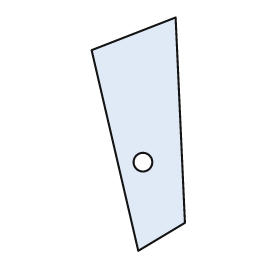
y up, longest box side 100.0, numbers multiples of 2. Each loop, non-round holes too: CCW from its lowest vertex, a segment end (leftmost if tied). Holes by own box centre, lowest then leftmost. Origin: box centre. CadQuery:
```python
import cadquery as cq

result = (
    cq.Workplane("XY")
    .moveTo(0.0, -50.0)
    .lineTo(20.0, -38.0)
    .lineTo(16.0, 50.0)
    .lineTo(-20.0, 36.0)
    .close()
    .moveTo(2.0, -12.0)
    .circle(4.0)
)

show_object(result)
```